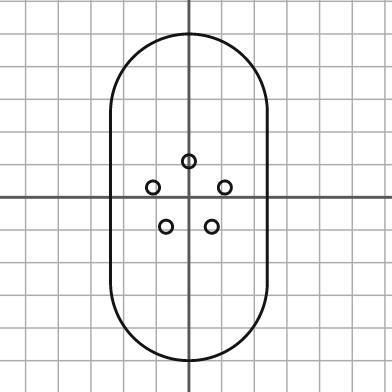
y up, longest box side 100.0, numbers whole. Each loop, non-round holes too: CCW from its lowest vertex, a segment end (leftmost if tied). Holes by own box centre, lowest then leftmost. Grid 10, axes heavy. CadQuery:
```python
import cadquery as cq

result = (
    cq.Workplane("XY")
    .moveTo(-24.0, -26.0)
    .threePointArc((0.0, -50.0), (24.0, -26.0))
    .lineTo(24.0, 26.0)
    .threePointArc((0.0, 50.0), (-24.0, 26.0))
    .close()
    .moveTo(-7.0, -9.0)
    .circle(2.0)
    .moveTo(7.0, -9.0)
    .circle(2.0)
    .moveTo(-11.0, 3.0)
    .circle(2.0)
    .moveTo(11.0, 3.0)
    .circle(2.0)
    .moveTo(0.0, 11.0)
    .circle(2.0)
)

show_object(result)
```